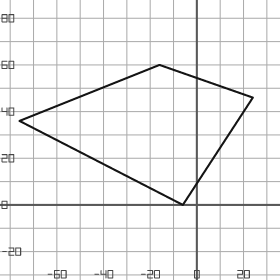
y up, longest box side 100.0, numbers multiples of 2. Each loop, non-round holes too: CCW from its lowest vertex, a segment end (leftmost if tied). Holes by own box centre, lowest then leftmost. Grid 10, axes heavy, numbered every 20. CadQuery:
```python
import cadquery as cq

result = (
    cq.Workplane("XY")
    .moveTo(-6.0, 0.0)
    .lineTo(24.0, 46.0)
    .lineTo(-16.0, 60.0)
    .lineTo(-76.0, 36.0)
    .close()
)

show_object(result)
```